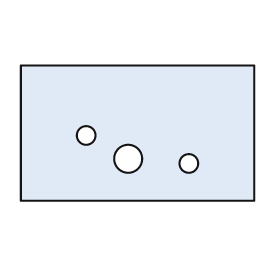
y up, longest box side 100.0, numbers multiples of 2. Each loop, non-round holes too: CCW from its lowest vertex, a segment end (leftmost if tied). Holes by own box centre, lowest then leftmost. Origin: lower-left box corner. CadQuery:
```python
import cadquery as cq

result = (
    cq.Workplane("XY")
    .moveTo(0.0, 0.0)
    .lineTo(100.0, 0.0)
    .lineTo(100.0, 58.0)
    .lineTo(0.0, 58.0)
    .close()
    .moveTo(72.0, 16.0)
    .circle(4.0)
    .moveTo(46.0, 18.0)
    .circle(6.0)
    .moveTo(28.0, 28.0)
    .circle(4.0)
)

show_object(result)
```